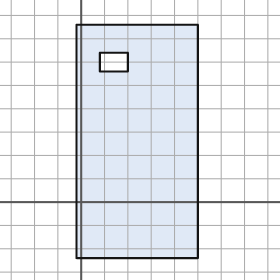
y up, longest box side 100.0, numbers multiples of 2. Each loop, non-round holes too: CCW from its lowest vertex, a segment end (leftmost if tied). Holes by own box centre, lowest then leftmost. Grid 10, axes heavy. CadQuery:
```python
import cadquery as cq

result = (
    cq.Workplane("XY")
    .moveTo(-2.0, -24.0)
    .lineTo(50.0, -24.0)
    .lineTo(50.0, 76.0)
    .lineTo(-2.0, 76.0)
    .close()
    .moveTo(8.0, 56.0)
    .lineTo(20.0, 56.0)
    .lineTo(20.0, 64.0)
    .lineTo(8.0, 64.0)
    .close()
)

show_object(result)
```